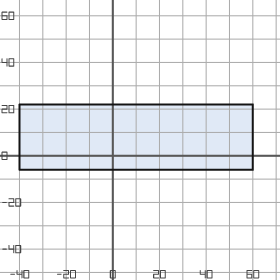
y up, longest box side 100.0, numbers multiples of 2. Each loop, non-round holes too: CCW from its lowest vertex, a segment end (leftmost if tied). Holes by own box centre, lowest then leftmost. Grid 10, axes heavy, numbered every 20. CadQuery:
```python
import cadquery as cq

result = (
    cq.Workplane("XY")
    .moveTo(-40.0, -6.0)
    .lineTo(60.0, -6.0)
    .lineTo(60.0, 22.0)
    .lineTo(-40.0, 22.0)
    .close()
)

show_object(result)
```